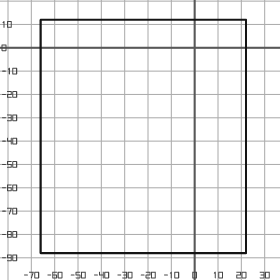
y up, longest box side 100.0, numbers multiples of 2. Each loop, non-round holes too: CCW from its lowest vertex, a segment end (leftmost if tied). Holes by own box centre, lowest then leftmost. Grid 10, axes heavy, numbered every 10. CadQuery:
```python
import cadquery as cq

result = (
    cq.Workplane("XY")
    .moveTo(-66.0, -88.0)
    .lineTo(22.0, -88.0)
    .lineTo(22.0, 12.0)
    .lineTo(-66.0, 12.0)
    .close()
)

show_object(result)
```